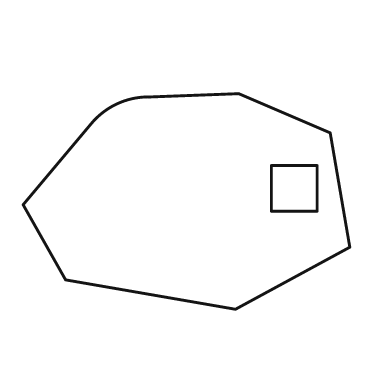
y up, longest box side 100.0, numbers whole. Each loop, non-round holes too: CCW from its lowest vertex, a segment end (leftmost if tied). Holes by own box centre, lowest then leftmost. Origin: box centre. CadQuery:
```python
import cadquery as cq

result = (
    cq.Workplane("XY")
    .moveTo(15.0, -33.0)
    .lineTo(50.0, -14.0)
    .lineTo(44.0, 21.0)
    .lineTo(16.0, 33.0)
    .lineTo(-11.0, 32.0)
    .threePointArc((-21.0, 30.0), (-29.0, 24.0))
    .lineTo(-50.0, -1.0)
    .lineTo(-37.0, -24.0)
    .close()
    .moveTo(26.0, -3.0)
    .lineTo(40.0, -3.0)
    .lineTo(40.0, 11.0)
    .lineTo(26.0, 11.0)
    .close()
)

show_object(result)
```